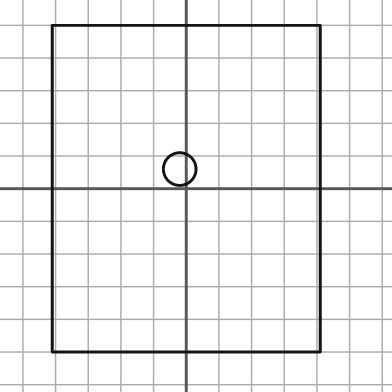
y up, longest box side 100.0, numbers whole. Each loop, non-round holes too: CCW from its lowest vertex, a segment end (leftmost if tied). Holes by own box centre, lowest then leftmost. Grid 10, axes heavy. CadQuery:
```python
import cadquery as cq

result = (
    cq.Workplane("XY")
    .moveTo(-41.0, -50.0)
    .lineTo(41.0, -50.0)
    .lineTo(41.0, 50.0)
    .lineTo(-41.0, 50.0)
    .close()
    .moveTo(-2.0, 6.0)
    .circle(5.0)
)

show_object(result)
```